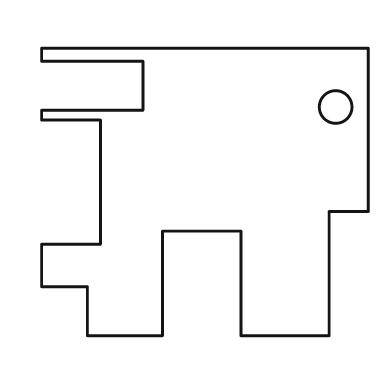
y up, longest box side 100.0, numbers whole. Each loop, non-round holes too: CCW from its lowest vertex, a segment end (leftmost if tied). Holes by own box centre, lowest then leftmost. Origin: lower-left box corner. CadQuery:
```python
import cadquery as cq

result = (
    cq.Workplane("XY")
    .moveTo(14.0, 0.0)
    .lineTo(37.0, 0.0)
    .lineTo(37.0, 32.0)
    .lineTo(61.0, 32.0)
    .lineTo(61.0, 0.0)
    .lineTo(88.0, 0.0)
    .lineTo(88.0, 38.0)
    .lineTo(100.0, 38.0)
    .lineTo(100.0, 88.0)
    .lineTo(0.0, 88.0)
    .lineTo(0.0, 84.0)
    .lineTo(31.0, 84.0)
    .lineTo(31.0, 69.0)
    .lineTo(0.0, 69.0)
    .lineTo(0.0, 66.0)
    .lineTo(18.0, 66.0)
    .lineTo(18.0, 28.0)
    .lineTo(0.0, 28.0)
    .lineTo(0.0, 15.0)
    .lineTo(14.0, 15.0)
    .close()
    .moveTo(90.0, 70.0)
    .circle(5.0)
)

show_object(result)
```